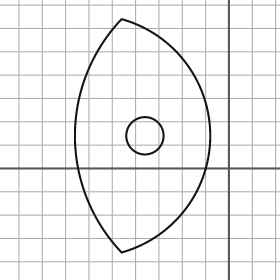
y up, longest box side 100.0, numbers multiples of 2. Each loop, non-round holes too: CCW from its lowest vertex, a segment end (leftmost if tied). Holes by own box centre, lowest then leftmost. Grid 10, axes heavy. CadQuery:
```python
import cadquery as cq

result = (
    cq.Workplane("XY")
    .moveTo(-46.0, -36.0)
    .threePointArc((-8.0, 14.0), (-46.0, 64.0))
    .threePointArc((-66.0, 14.0), (-46.0, -36.0))
    .close()
    .moveTo(-36.0, 14.0)
    .circle(8.0)
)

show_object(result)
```